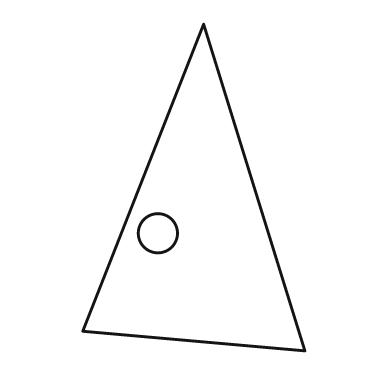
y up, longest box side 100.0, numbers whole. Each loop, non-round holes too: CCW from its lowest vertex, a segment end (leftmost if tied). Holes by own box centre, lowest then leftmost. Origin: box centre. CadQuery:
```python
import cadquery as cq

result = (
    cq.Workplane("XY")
    .moveTo(34.0, -50.0)
    .lineTo(3.0, 50.0)
    .lineTo(-34.0, -44.0)
    .close()
    .moveTo(-11.0, -14.0)
    .circle(6.0)
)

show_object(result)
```